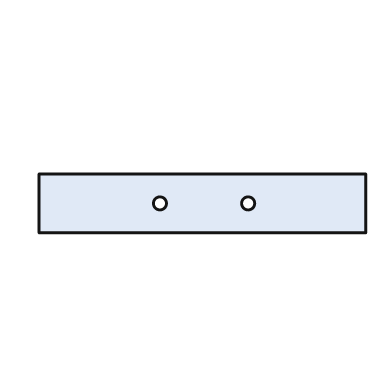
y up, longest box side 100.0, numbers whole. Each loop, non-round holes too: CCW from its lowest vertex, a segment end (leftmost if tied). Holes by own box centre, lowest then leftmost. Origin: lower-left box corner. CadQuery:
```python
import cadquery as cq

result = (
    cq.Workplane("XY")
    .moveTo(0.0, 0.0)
    .lineTo(100.0, 0.0)
    .lineTo(100.0, 18.0)
    .lineTo(0.0, 18.0)
    .close()
    .moveTo(37.0, 9.0)
    .circle(2.0)
    .moveTo(64.0, 9.0)
    .circle(2.0)
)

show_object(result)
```